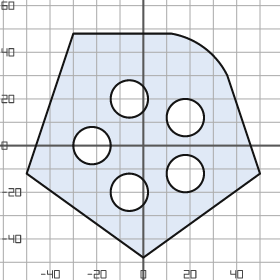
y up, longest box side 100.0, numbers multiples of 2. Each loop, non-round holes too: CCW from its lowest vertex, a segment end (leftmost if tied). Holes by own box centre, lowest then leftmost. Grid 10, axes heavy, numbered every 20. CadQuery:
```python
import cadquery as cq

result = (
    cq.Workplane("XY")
    .moveTo(0.0, -48.0)
    .lineTo(50.0, -12.0)
    .lineTo(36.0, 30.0)
    .threePointArc((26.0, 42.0), (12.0, 48.0))
    .lineTo(-30.0, 48.0)
    .lineTo(-50.0, -12.0)
    .close()
    .moveTo(-6.0, -20.0)
    .circle(8.0)
    .moveTo(18.0, -12.0)
    .circle(8.0)
    .moveTo(-22.0, 0.0)
    .circle(8.0)
    .moveTo(18.0, 12.0)
    .circle(8.0)
    .moveTo(-6.0, 20.0)
    .circle(8.0)
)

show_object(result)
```